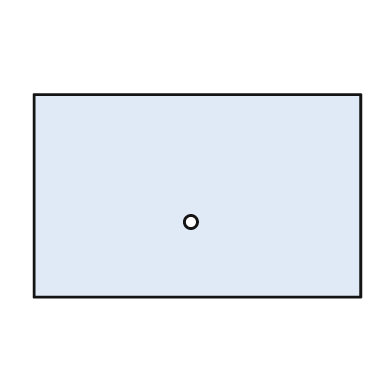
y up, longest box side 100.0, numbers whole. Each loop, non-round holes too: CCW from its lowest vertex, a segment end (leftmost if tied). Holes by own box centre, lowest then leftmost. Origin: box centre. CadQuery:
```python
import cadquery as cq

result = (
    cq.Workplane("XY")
    .moveTo(-50.0, -31.0)
    .lineTo(50.0, -31.0)
    .lineTo(50.0, 31.0)
    .lineTo(-50.0, 31.0)
    .close()
    .moveTo(-2.0, -8.0)
    .circle(2.0)
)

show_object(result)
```